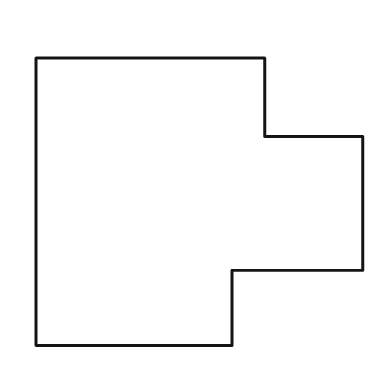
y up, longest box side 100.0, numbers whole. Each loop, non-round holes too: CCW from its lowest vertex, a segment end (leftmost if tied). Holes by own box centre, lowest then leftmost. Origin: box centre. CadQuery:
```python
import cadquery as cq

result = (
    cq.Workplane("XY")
    .moveTo(-50.0, -44.0)
    .lineTo(10.0, -44.0)
    .lineTo(10.0, -21.0)
    .lineTo(50.0, -21.0)
    .lineTo(50.0, 20.0)
    .lineTo(20.0, 20.0)
    .lineTo(20.0, 44.0)
    .lineTo(-50.0, 44.0)
    .close()
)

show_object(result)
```